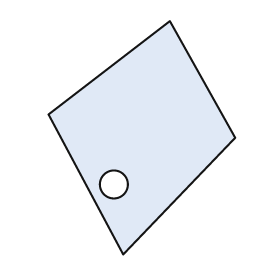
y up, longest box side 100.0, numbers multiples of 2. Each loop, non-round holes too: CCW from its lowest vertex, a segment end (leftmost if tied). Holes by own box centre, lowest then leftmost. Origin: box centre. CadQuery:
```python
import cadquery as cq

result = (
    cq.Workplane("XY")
    .moveTo(-8.0, -50.0)
    .lineTo(40.0, 0.0)
    .lineTo(12.0, 50.0)
    .lineTo(-40.0, 10.0)
    .close()
    .moveTo(-12.0, -20.0)
    .circle(6.0)
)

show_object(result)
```